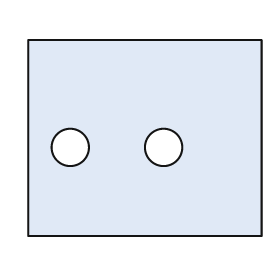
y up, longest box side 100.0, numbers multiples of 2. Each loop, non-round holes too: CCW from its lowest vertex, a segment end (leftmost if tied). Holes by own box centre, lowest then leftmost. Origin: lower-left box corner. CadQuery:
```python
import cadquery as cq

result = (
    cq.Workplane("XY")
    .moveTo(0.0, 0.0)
    .lineTo(100.0, 0.0)
    .lineTo(100.0, 84.0)
    .lineTo(0.0, 84.0)
    .close()
    .moveTo(18.0, 38.0)
    .circle(8.0)
    .moveTo(58.0, 38.0)
    .circle(8.0)
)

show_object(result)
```